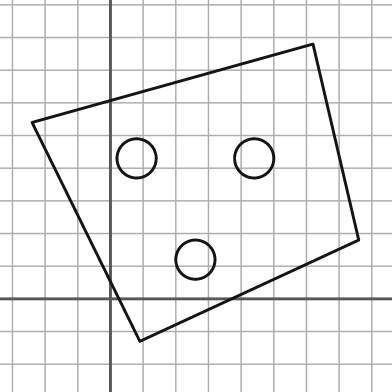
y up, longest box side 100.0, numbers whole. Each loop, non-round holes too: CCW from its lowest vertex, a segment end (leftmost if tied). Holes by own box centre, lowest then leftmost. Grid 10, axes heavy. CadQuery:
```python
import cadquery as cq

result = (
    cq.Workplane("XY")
    .moveTo(9.0, -13.0)
    .lineTo(76.0, 18.0)
    .lineTo(62.0, 78.0)
    .lineTo(-24.0, 54.0)
    .close()
    .moveTo(26.0, 12.0)
    .circle(6.0)
    .moveTo(8.0, 43.0)
    .circle(6.0)
    .moveTo(44.0, 43.0)
    .circle(6.0)
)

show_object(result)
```